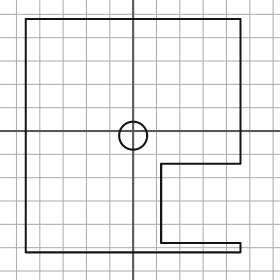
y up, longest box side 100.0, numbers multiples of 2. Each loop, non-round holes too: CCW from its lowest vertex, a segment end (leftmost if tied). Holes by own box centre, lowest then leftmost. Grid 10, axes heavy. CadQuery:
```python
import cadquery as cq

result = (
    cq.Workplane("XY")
    .moveTo(-46.0, -52.0)
    .lineTo(46.0, -52.0)
    .lineTo(46.0, -48.0)
    .lineTo(12.0, -48.0)
    .lineTo(12.0, -14.0)
    .lineTo(46.0, -14.0)
    .lineTo(46.0, 48.0)
    .lineTo(-46.0, 48.0)
    .close()
    .moveTo(0.0, -2.0)
    .circle(6.0)
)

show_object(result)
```